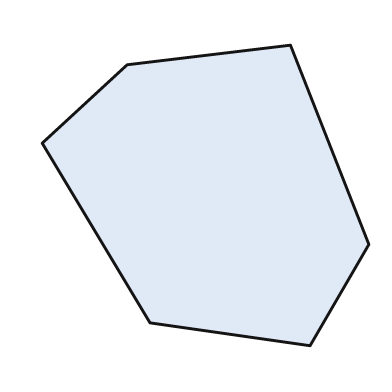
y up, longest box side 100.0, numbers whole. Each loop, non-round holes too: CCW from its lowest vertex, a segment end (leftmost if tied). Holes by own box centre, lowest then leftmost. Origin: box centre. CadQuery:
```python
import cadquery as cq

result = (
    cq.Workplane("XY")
    .moveTo(32.0, -46.0)
    .lineTo(50.0, -15.0)
    .lineTo(26.0, 46.0)
    .lineTo(-24.0, 40.0)
    .lineTo(-50.0, 16.0)
    .lineTo(-17.0, -39.0)
    .close()
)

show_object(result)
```